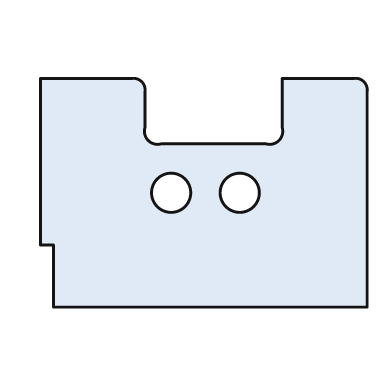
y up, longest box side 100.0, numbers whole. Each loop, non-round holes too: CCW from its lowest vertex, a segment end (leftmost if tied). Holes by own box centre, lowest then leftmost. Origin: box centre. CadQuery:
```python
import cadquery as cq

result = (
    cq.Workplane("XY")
    .moveTo(-46.0, -35.0)
    .lineTo(50.0, -35.0)
    .lineTo(50.0, 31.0)
    .threePointArc((49.0, 34.0), (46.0, 35.0))
    .lineTo(24.0, 35.0)
    .lineTo(24.0, 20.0)
    .threePointArc((23.0, 16.0), (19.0, 15.0))
    .lineTo(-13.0, 15.0)
    .threePointArc((-17.0, 16.0), (-18.0, 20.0))
    .lineTo(-18.0, 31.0)
    .threePointArc((-19.0, 34.0), (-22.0, 35.0))
    .lineTo(-50.0, 35.0)
    .lineTo(-50.0, -16.0)
    .lineTo(-46.0, -16.0)
    .close()
    .moveTo(-10.0, 0.0)
    .circle(6.0)
    .moveTo(11.0, 0.0)
    .circle(6.0)
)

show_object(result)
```